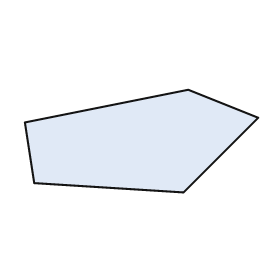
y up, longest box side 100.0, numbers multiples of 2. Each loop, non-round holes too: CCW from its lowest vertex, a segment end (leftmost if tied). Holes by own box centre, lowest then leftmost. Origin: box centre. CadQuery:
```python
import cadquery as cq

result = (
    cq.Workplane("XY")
    .moveTo(18.0, -22.0)
    .lineTo(50.0, 10.0)
    .lineTo(20.0, 22.0)
    .lineTo(-50.0, 8.0)
    .lineTo(-46.0, -18.0)
    .close()
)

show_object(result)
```